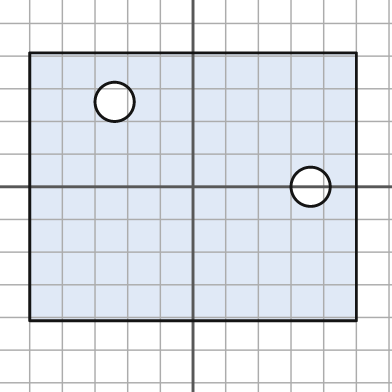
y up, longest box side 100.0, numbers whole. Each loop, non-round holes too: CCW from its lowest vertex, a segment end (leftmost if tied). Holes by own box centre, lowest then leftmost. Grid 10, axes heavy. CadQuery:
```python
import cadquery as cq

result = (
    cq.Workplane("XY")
    .moveTo(-50.0, -41.0)
    .lineTo(50.0, -41.0)
    .lineTo(50.0, 41.0)
    .lineTo(-50.0, 41.0)
    .close()
    .moveTo(36.0, 0.0)
    .circle(6.0)
    .moveTo(-24.0, 26.0)
    .circle(6.0)
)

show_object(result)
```